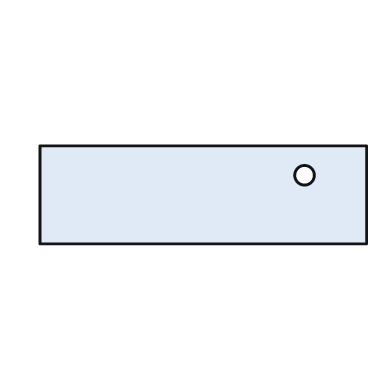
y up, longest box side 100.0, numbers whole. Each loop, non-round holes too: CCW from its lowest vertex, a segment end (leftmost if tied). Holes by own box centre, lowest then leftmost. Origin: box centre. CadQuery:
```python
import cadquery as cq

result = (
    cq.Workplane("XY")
    .moveTo(-50.0, -15.0)
    .lineTo(50.0, -15.0)
    .lineTo(50.0, 15.0)
    .lineTo(-50.0, 15.0)
    .close()
    .moveTo(31.0, 6.0)
    .circle(3.0)
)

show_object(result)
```